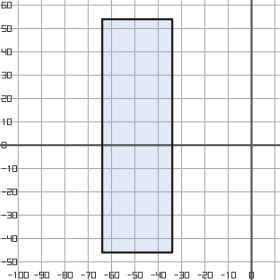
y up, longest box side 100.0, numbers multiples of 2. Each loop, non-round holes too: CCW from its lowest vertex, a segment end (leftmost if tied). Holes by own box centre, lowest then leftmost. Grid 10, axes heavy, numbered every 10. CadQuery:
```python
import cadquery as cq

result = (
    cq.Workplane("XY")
    .moveTo(-64.0, -46.0)
    .lineTo(-34.0, -46.0)
    .lineTo(-34.0, 54.0)
    .lineTo(-64.0, 54.0)
    .close()
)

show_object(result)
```